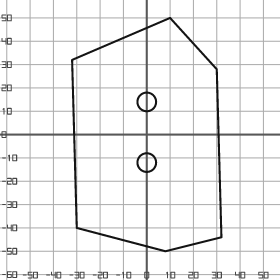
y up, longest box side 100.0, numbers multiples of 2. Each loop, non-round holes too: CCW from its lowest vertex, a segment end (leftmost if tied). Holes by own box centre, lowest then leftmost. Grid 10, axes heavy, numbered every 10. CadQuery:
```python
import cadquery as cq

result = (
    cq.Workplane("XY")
    .moveTo(8.0, -50.0)
    .lineTo(32.0, -44.0)
    .lineTo(30.0, 28.0)
    .lineTo(10.0, 50.0)
    .lineTo(-32.0, 32.0)
    .lineTo(-30.0, -40.0)
    .close()
    .moveTo(0.0, -12.0)
    .circle(4.0)
    .moveTo(0.0, 14.0)
    .circle(4.0)
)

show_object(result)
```